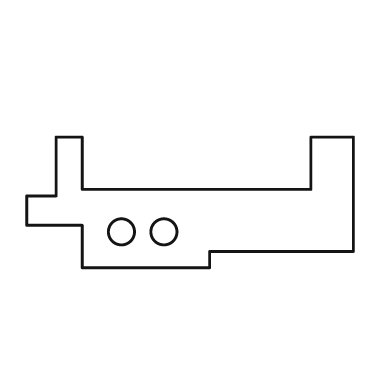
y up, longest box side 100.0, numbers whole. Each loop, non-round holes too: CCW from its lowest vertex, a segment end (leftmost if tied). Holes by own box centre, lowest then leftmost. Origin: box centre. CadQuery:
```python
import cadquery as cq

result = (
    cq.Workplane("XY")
    .moveTo(-33.0, -20.0)
    .lineTo(6.0, -20.0)
    .lineTo(6.0, -15.0)
    .lineTo(50.0, -15.0)
    .lineTo(50.0, 20.0)
    .lineTo(37.0, 20.0)
    .lineTo(37.0, 4.0)
    .lineTo(-33.0, 4.0)
    .lineTo(-33.0, 20.0)
    .lineTo(-41.0, 20.0)
    .lineTo(-41.0, 2.0)
    .lineTo(-50.0, 2.0)
    .lineTo(-50.0, -7.0)
    .lineTo(-33.0, -7.0)
    .close()
    .moveTo(-21.0, -9.0)
    .circle(4.0)
    .moveTo(-8.0, -9.0)
    .circle(4.0)
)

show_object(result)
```